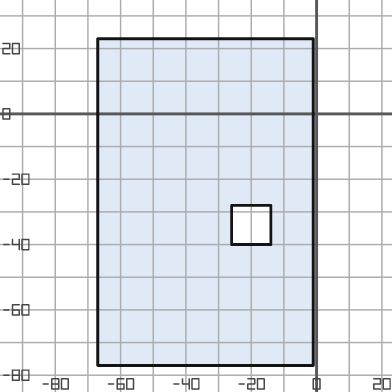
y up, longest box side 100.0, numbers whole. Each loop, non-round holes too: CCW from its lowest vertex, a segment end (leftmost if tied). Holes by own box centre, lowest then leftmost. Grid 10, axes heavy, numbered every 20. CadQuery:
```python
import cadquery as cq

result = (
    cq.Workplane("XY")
    .moveTo(-67.0, -77.0)
    .lineTo(-1.0, -77.0)
    .lineTo(-1.0, 23.0)
    .lineTo(-67.0, 23.0)
    .close()
    .moveTo(-26.0, -40.0)
    .lineTo(-14.0, -40.0)
    .lineTo(-14.0, -28.0)
    .lineTo(-26.0, -28.0)
    .close()
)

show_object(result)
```